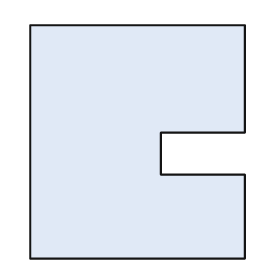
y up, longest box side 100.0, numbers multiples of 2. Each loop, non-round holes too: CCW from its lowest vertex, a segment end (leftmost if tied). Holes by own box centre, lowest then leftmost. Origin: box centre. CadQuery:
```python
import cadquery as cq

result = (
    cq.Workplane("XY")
    .moveTo(-46.0, -50.0)
    .lineTo(46.0, -50.0)
    .lineTo(46.0, -14.0)
    .lineTo(10.0, -14.0)
    .lineTo(10.0, 4.0)
    .lineTo(46.0, 4.0)
    .lineTo(46.0, 50.0)
    .lineTo(-46.0, 50.0)
    .close()
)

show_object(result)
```